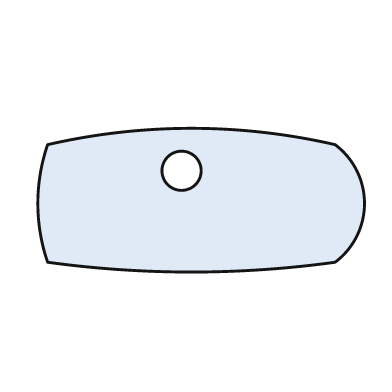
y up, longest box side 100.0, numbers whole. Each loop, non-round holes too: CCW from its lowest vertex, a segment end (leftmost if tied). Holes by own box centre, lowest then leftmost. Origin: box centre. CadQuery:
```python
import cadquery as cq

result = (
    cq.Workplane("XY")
    .moveTo(-47.0, -19.0)
    .threePointArc((-3.0, -22.0), (41.0, -19.0))
    .threePointArc((50.0, -1.0), (41.0, 17.0))
    .threePointArc((-3.0, 22.0), (-47.0, 17.0))
    .threePointArc((-50.0, -1.0), (-47.0, -19.0))
    .close()
    .moveTo(-6.0, 9.0)
    .circle(6.0)
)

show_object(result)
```